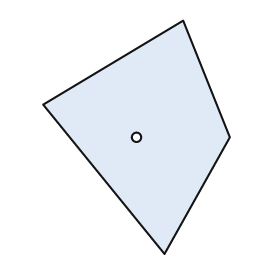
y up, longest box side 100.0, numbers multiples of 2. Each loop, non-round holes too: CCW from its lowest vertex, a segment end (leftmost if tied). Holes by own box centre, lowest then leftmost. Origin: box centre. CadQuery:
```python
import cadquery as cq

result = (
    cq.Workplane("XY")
    .moveTo(12.0, -50.0)
    .lineTo(40.0, 0.0)
    .lineTo(20.0, 50.0)
    .lineTo(-40.0, 14.0)
    .close()
    .moveTo(0.0, 0.0)
    .circle(2.0)
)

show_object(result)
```